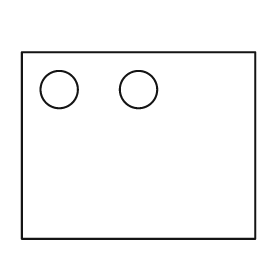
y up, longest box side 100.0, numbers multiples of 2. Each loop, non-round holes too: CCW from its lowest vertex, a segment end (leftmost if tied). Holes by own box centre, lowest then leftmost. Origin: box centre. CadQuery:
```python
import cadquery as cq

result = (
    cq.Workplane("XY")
    .moveTo(-50.0, -40.0)
    .lineTo(50.0, -40.0)
    .lineTo(50.0, 40.0)
    .lineTo(-50.0, 40.0)
    .close()
    .moveTo(-34.0, 24.0)
    .circle(8.0)
    .moveTo(0.0, 24.0)
    .circle(8.0)
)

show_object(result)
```